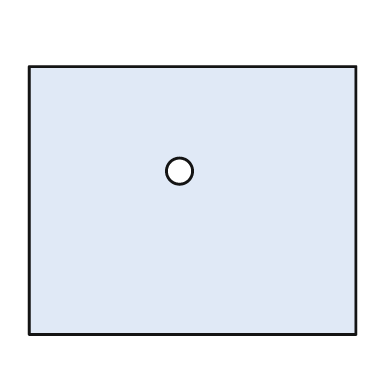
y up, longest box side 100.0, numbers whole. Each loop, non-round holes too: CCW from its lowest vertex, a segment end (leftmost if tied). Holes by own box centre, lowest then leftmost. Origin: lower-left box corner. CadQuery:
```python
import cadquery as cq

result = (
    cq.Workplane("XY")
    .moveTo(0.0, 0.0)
    .lineTo(100.0, 0.0)
    .lineTo(100.0, 82.0)
    .lineTo(0.0, 82.0)
    .close()
    .moveTo(46.0, 50.0)
    .circle(4.0)
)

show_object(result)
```